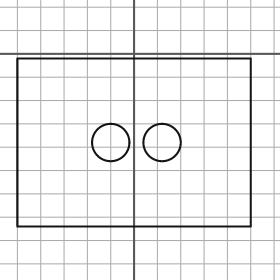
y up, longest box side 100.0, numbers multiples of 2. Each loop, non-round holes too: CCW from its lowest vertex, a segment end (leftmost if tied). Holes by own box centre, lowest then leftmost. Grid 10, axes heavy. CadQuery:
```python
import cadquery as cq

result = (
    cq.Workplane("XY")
    .moveTo(-50.0, -74.0)
    .lineTo(50.0, -74.0)
    .lineTo(50.0, -2.0)
    .lineTo(-50.0, -2.0)
    .close()
    .moveTo(-10.0, -38.0)
    .circle(8.0)
    .moveTo(12.0, -38.0)
    .circle(8.0)
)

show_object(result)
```